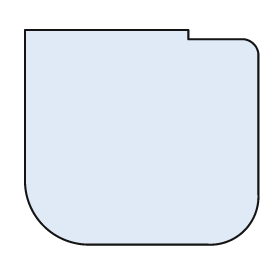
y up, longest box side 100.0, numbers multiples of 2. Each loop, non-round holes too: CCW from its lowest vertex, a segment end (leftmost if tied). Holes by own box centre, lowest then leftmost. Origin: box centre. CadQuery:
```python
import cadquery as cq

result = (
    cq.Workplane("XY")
    .moveTo(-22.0, -46.0)
    .lineTo(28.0, -46.0)
    .threePointArc((44.0, -40.0), (50.0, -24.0))
    .lineTo(50.0, 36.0)
    .threePointArc((48.0, 40.0), (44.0, 42.0))
    .lineTo(20.0, 42.0)
    .lineTo(20.0, 46.0)
    .lineTo(-50.0, 46.0)
    .lineTo(-50.0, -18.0)
    .threePointArc((-42.0, -38.0), (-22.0, -46.0))
    .close()
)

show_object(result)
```